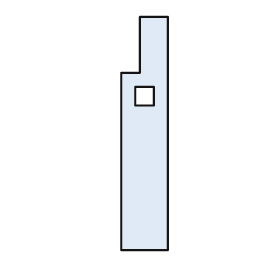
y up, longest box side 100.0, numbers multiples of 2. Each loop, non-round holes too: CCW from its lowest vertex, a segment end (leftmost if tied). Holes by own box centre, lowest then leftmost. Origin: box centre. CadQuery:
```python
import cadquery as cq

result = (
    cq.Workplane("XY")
    .moveTo(-10.0, -50.0)
    .lineTo(10.0, -50.0)
    .lineTo(10.0, 50.0)
    .lineTo(-2.0, 50.0)
    .lineTo(-2.0, 26.0)
    .lineTo(-10.0, 26.0)
    .close()
    .moveTo(-4.0, 12.0)
    .lineTo(4.0, 12.0)
    .lineTo(4.0, 20.0)
    .lineTo(-4.0, 20.0)
    .close()
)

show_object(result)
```